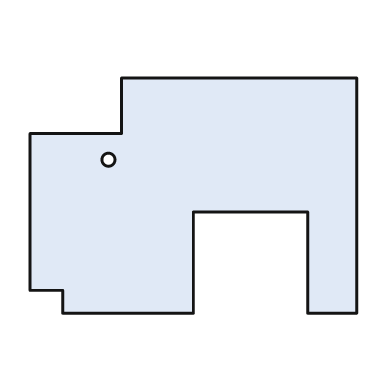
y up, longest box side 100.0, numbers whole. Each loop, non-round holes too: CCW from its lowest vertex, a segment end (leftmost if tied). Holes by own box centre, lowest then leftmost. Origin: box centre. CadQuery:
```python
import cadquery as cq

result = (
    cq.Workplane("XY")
    .moveTo(-40.0, -36.0)
    .lineTo(0.0, -36.0)
    .lineTo(0.0, -5.0)
    .lineTo(35.0, -5.0)
    .lineTo(35.0, -36.0)
    .lineTo(50.0, -36.0)
    .lineTo(50.0, 36.0)
    .lineTo(-22.0, 36.0)
    .lineTo(-22.0, 19.0)
    .lineTo(-50.0, 19.0)
    .lineTo(-50.0, -29.0)
    .lineTo(-40.0, -29.0)
    .close()
    .moveTo(-26.0, 11.0)
    .circle(2.0)
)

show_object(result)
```